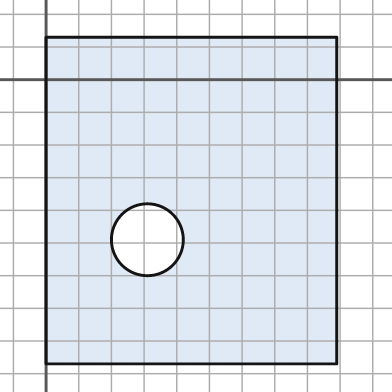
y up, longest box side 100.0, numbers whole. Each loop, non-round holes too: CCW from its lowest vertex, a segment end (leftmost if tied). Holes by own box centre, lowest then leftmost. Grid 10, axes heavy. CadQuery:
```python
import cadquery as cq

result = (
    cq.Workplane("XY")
    .moveTo(0.0, -87.0)
    .lineTo(89.0, -87.0)
    .lineTo(89.0, 13.0)
    .lineTo(0.0, 13.0)
    .close()
    .moveTo(31.0, -49.0)
    .circle(11.0)
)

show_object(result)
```